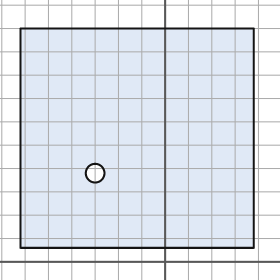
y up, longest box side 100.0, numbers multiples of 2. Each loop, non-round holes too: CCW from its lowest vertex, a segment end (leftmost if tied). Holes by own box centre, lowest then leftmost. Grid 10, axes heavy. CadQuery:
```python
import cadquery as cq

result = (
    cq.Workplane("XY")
    .moveTo(-62.0, 6.0)
    .lineTo(38.0, 6.0)
    .lineTo(38.0, 100.0)
    .lineTo(-62.0, 100.0)
    .close()
    .moveTo(-30.0, 38.0)
    .circle(4.0)
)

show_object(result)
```